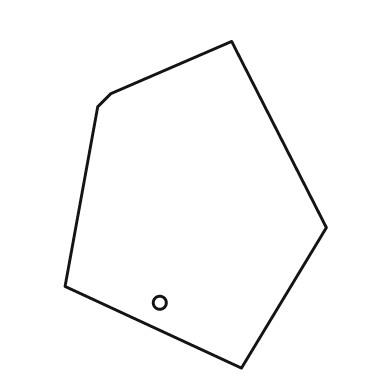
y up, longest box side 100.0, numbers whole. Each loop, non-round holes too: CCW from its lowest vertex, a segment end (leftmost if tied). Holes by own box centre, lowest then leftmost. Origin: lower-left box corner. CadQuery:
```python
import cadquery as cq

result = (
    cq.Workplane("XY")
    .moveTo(54.0, 0.0)
    .lineTo(80.0, 43.0)
    .lineTo(51.0, 100.0)
    .lineTo(14.0, 84.0)
    .lineTo(10.0, 80.0)
    .lineTo(0.0, 25.0)
    .close()
    .moveTo(29.0, 20.0)
    .circle(2.0)
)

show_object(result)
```